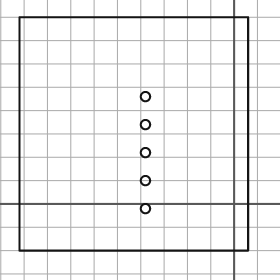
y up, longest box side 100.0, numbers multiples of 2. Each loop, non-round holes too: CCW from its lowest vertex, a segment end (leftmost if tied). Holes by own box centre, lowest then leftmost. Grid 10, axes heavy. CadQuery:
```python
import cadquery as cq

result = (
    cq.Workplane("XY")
    .moveTo(-92.0, -20.0)
    .lineTo(6.0, -20.0)
    .lineTo(6.0, 80.0)
    .lineTo(-92.0, 80.0)
    .close()
    .moveTo(-38.0, -2.0)
    .circle(2.0)
    .moveTo(-38.0, 10.0)
    .circle(2.0)
    .moveTo(-38.0, 22.0)
    .circle(2.0)
    .moveTo(-38.0, 34.0)
    .circle(2.0)
    .moveTo(-38.0, 46.0)
    .circle(2.0)
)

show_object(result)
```